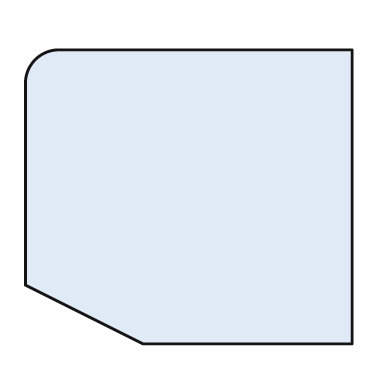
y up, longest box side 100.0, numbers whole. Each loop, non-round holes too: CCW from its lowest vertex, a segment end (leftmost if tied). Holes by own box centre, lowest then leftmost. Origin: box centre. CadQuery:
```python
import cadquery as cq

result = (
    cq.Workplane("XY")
    .moveTo(-14.0, -45.0)
    .lineTo(50.0, -45.0)
    .lineTo(50.0, 45.0)
    .lineTo(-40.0, 45.0)
    .threePointArc((-47.0, 42.0), (-50.0, 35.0))
    .lineTo(-50.0, -27.0)
    .close()
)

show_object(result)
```